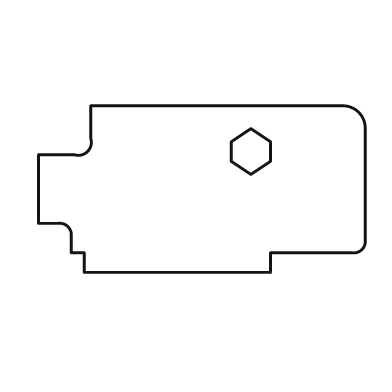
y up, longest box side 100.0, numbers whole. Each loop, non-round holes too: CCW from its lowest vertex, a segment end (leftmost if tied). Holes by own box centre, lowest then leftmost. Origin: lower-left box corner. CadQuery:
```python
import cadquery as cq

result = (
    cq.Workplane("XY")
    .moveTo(14.0, 0.0)
    .lineTo(71.0, 0.0)
    .lineTo(71.0, 6.0)
    .lineTo(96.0, 6.0)
    .threePointArc((99.0, 7.0), (100.0, 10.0))
    .lineTo(100.0, 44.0)
    .threePointArc((98.0, 49.0), (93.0, 51.0))
    .lineTo(16.0, 51.0)
    .lineTo(16.0, 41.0)
    .threePointArc((15.0, 37.0), (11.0, 36.0))
    .lineTo(0.0, 36.0)
    .lineTo(0.0, 15.0)
    .lineTo(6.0, 15.0)
    .threePointArc((9.0, 14.0), (10.0, 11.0))
    .lineTo(10.0, 6.0)
    .lineTo(14.0, 6.0)
    .close()
    .moveTo(65.0, 30.0)
    .lineTo(71.0, 34.0)
    .lineTo(71.0, 40.0)
    .lineTo(65.0, 44.0)
    .lineTo(59.0, 40.0)
    .lineTo(59.0, 34.0)
    .close()
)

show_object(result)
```